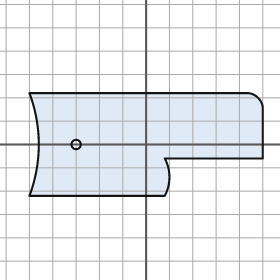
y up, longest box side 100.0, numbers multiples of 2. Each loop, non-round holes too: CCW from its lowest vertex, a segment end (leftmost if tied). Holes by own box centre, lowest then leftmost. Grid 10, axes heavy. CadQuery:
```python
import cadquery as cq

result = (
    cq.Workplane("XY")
    .moveTo(-50.0, -22.0)
    .lineTo(8.0, -22.0)
    .threePointArc((10.0, -14.0), (8.0, -6.0))
    .lineTo(50.0, -6.0)
    .lineTo(50.0, 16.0)
    .threePointArc((48.0, 20.0), (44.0, 22.0))
    .lineTo(-50.0, 22.0)
    .threePointArc((-46.0, 0.0), (-50.0, -22.0))
    .close()
    .moveTo(-30.0, 0.0)
    .circle(2.0)
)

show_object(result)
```